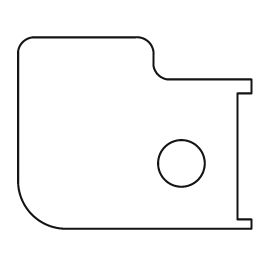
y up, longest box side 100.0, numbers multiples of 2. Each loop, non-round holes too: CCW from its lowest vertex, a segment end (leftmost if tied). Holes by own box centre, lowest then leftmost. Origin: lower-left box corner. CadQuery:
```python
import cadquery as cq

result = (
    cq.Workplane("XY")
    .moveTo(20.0, 0.0)
    .lineTo(100.0, 0.0)
    .lineTo(100.0, 4.0)
    .lineTo(94.0, 4.0)
    .lineTo(94.0, 58.0)
    .lineTo(100.0, 58.0)
    .lineTo(100.0, 64.0)
    .lineTo(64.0, 64.0)
    .threePointArc((60.0, 66.0), (58.0, 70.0))
    .lineTo(58.0, 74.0)
    .threePointArc((56.0, 80.0), (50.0, 82.0))
    .lineTo(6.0, 82.0)
    .threePointArc((2.0, 80.0), (0.0, 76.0))
    .lineTo(0.0, 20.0)
    .threePointArc((6.0, 6.0), (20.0, 0.0))
    .close()
    .moveTo(70.0, 28.0)
    .circle(10.0)
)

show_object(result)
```